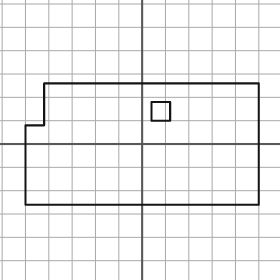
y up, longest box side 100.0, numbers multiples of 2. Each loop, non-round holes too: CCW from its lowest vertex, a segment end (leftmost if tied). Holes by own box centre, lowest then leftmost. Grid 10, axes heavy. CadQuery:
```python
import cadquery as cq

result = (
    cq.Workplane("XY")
    .moveTo(-50.0, -26.0)
    .lineTo(50.0, -26.0)
    .lineTo(50.0, 26.0)
    .lineTo(-42.0, 26.0)
    .lineTo(-42.0, 8.0)
    .lineTo(-50.0, 8.0)
    .close()
    .moveTo(4.0, 10.0)
    .lineTo(12.0, 10.0)
    .lineTo(12.0, 18.0)
    .lineTo(4.0, 18.0)
    .close()
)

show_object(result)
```